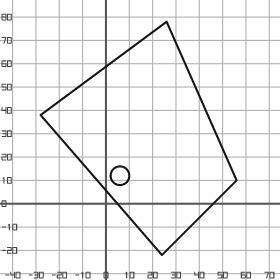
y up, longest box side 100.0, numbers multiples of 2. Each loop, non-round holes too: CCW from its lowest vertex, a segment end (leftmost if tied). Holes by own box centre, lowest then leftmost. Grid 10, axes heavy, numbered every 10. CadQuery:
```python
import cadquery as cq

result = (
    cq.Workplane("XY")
    .moveTo(24.0, -22.0)
    .lineTo(56.0, 10.0)
    .lineTo(26.0, 78.0)
    .lineTo(-28.0, 38.0)
    .close()
    .moveTo(6.0, 12.0)
    .circle(4.0)
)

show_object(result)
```